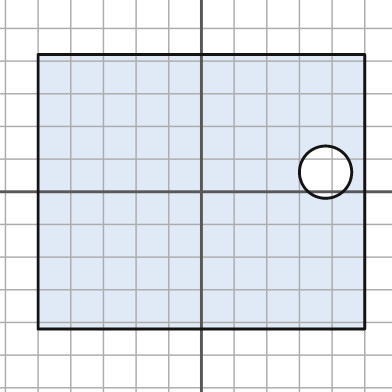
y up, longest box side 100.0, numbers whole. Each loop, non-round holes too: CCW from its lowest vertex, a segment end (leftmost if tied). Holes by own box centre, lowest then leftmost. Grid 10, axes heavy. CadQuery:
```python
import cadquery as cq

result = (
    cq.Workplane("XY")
    .moveTo(-50.0, -42.0)
    .lineTo(50.0, -42.0)
    .lineTo(50.0, 42.0)
    .lineTo(-50.0, 42.0)
    .close()
    .moveTo(38.0, 6.0)
    .circle(8.0)
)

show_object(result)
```